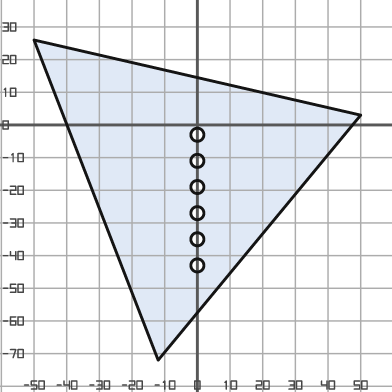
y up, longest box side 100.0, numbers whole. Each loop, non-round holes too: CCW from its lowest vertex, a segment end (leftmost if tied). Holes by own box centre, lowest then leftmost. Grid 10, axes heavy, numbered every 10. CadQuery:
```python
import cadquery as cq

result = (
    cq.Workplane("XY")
    .moveTo(-12.0, -72.0)
    .lineTo(50.0, 3.0)
    .lineTo(-50.0, 26.0)
    .close()
    .moveTo(0.0, -43.0)
    .circle(2.0)
    .moveTo(0.0, -35.0)
    .circle(2.0)
    .moveTo(0.0, -27.0)
    .circle(2.0)
    .moveTo(0.0, -19.0)
    .circle(2.0)
    .moveTo(0.0, -11.0)
    .circle(2.0)
    .moveTo(0.0, -3.0)
    .circle(2.0)
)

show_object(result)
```